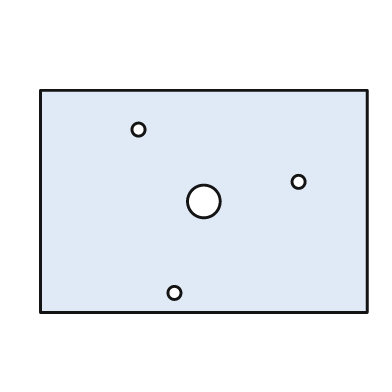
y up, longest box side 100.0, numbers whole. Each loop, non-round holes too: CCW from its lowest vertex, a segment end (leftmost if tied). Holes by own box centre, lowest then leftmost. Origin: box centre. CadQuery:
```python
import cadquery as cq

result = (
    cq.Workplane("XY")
    .moveTo(-50.0, -34.0)
    .lineTo(50.0, -34.0)
    .lineTo(50.0, 34.0)
    .lineTo(-50.0, 34.0)
    .close()
    .moveTo(-9.0, -28.0)
    .circle(2.0)
    .moveTo(0.0, 0.0)
    .circle(5.0)
    .moveTo(29.0, 6.0)
    .circle(2.0)
    .moveTo(-20.0, 22.0)
    .circle(2.0)
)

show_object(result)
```